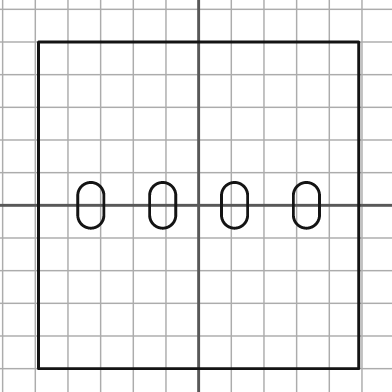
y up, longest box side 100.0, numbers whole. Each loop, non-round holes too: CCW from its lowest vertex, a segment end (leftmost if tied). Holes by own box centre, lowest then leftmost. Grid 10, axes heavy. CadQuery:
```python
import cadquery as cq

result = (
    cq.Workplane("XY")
    .moveTo(-49.0, -50.0)
    .lineTo(49.0, -50.0)
    .lineTo(49.0, 50.0)
    .lineTo(-49.0, 50.0)
    .close()
    .moveTo(-37.0, -3.0)
    .threePointArc((-33.0, -7.0), (-29.0, -3.0))
    .lineTo(-29.0, 3.0)
    .threePointArc((-33.0, 7.0), (-37.0, 3.0))
    .close()
    .moveTo(-15.0, -3.0)
    .threePointArc((-11.0, -7.0), (-7.0, -3.0))
    .lineTo(-7.0, 3.0)
    .threePointArc((-11.0, 7.0), (-15.0, 3.0))
    .close()
    .moveTo(7.0, -3.0)
    .threePointArc((11.0, -7.0), (15.0, -3.0))
    .lineTo(15.0, 3.0)
    .threePointArc((11.0, 7.0), (7.0, 3.0))
    .close()
    .moveTo(29.0, -3.0)
    .threePointArc((33.0, -7.0), (37.0, -3.0))
    .lineTo(37.0, 3.0)
    .threePointArc((33.0, 7.0), (29.0, 3.0))
    .close()
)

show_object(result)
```